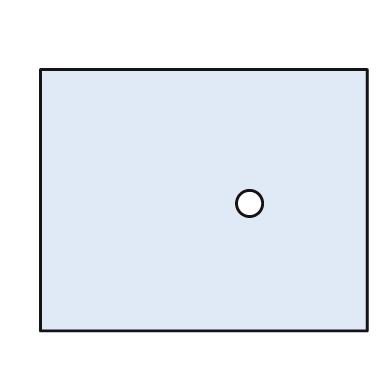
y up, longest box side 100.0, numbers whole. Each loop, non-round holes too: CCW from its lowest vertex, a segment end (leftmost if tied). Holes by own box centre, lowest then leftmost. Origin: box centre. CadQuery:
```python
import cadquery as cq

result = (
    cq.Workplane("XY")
    .moveTo(-50.0, -40.0)
    .lineTo(50.0, -40.0)
    .lineTo(50.0, 40.0)
    .lineTo(-50.0, 40.0)
    .close()
    .moveTo(14.0, -1.0)
    .circle(4.0)
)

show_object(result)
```